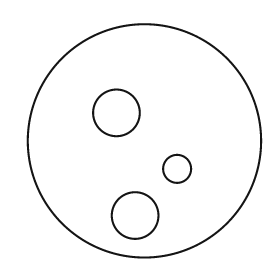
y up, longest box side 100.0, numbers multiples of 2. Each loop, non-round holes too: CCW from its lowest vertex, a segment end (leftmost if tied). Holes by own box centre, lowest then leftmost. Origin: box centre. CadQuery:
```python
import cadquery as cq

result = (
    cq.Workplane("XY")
    .moveTo(0.0, 0.0)
    .circle(50.0)
    .moveTo(-4.0, -32.0)
    .circle(10.0)
    .moveTo(14.0, -12.0)
    .circle(6.0)
    .moveTo(-12.0, 12.0)
    .circle(10.0)
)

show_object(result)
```